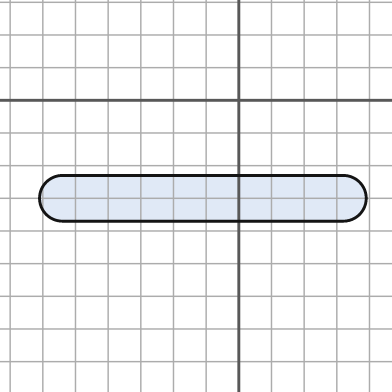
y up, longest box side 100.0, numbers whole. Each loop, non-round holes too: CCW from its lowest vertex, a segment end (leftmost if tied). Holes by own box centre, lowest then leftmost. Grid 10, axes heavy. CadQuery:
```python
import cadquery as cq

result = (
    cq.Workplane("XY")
    .moveTo(-54.0, -37.0)
    .lineTo(32.0, -37.0)
    .threePointArc((39.0, -30.0), (32.0, -23.0))
    .lineTo(-54.0, -23.0)
    .threePointArc((-61.0, -30.0), (-54.0, -37.0))
    .close()
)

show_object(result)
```